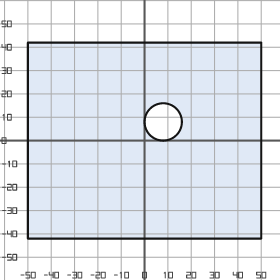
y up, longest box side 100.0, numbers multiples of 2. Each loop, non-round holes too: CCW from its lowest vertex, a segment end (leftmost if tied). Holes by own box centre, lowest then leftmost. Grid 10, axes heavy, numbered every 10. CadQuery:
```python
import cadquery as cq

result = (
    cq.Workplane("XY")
    .moveTo(-50.0, -42.0)
    .lineTo(50.0, -42.0)
    .lineTo(50.0, 42.0)
    .lineTo(-50.0, 42.0)
    .close()
    .moveTo(8.0, 8.0)
    .circle(8.0)
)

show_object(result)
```